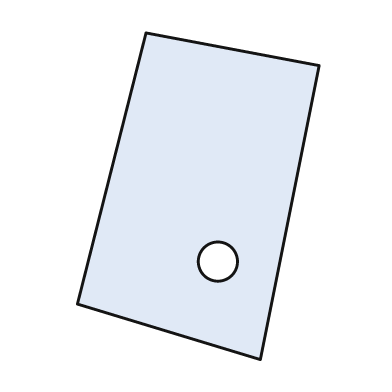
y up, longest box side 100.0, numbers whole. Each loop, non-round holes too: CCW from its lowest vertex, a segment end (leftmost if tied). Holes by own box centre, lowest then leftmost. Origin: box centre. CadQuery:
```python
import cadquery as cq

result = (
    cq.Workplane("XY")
    .moveTo(19.0, -50.0)
    .lineTo(37.0, 40.0)
    .lineTo(-16.0, 50.0)
    .lineTo(-37.0, -33.0)
    .close()
    .moveTo(6.0, -20.0)
    .circle(6.0)
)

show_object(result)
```